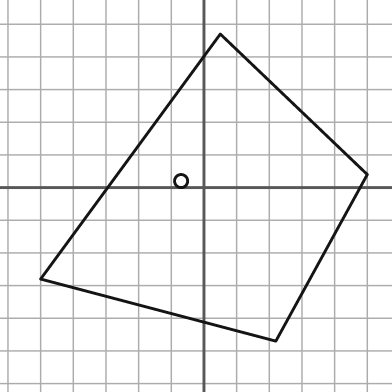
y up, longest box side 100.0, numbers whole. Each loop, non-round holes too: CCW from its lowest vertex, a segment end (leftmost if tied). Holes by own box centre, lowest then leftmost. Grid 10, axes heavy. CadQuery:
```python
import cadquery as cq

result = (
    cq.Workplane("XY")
    .moveTo(22.0, -47.0)
    .lineTo(50.0, 4.0)
    .lineTo(5.0, 47.0)
    .lineTo(-50.0, -28.0)
    .close()
    .moveTo(-7.0, 2.0)
    .circle(2.0)
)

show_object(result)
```